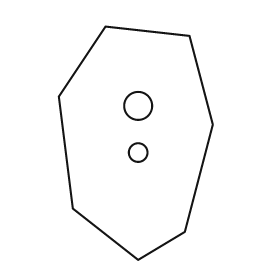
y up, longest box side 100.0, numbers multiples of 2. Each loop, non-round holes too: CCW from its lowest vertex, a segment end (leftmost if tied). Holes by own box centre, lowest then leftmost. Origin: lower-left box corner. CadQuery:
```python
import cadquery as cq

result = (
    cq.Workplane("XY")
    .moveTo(34.0, 0.0)
    .lineTo(54.0, 12.0)
    .lineTo(66.0, 58.0)
    .lineTo(56.0, 96.0)
    .lineTo(20.0, 100.0)
    .lineTo(0.0, 70.0)
    .lineTo(6.0, 22.0)
    .close()
    .moveTo(34.0, 46.0)
    .circle(4.0)
    .moveTo(34.0, 66.0)
    .circle(6.0)
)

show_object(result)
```